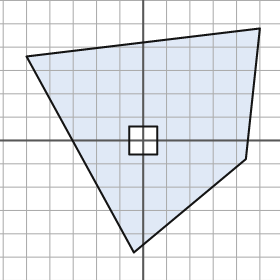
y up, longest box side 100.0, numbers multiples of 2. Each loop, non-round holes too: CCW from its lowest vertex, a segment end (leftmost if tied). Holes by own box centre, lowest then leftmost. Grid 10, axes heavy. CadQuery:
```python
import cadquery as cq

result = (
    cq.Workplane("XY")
    .moveTo(-4.0, -48.0)
    .lineTo(44.0, -8.0)
    .lineTo(50.0, 48.0)
    .lineTo(-50.0, 36.0)
    .close()
    .moveTo(-6.0, -6.0)
    .lineTo(6.0, -6.0)
    .lineTo(6.0, 6.0)
    .lineTo(-6.0, 6.0)
    .close()
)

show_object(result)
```